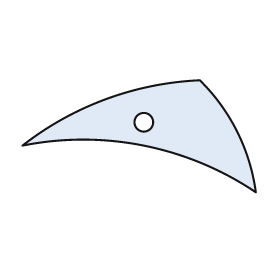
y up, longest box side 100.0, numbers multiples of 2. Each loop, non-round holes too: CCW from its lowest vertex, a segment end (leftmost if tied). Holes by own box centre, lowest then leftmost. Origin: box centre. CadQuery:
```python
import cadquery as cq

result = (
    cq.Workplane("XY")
    .moveTo(50.0, -24.0)
    .threePointArc((42.0, 2.0), (26.0, 24.0))
    .threePointArc((-14.0, 16.0), (-50.0, -4.0))
    .threePointArc((2.0, -4.0), (50.0, -24.0))
    .close()
    .moveTo(2.0, 6.0)
    .circle(4.0)
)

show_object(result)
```